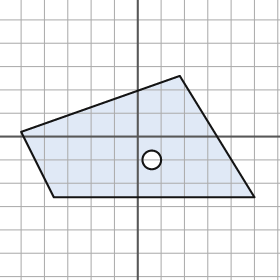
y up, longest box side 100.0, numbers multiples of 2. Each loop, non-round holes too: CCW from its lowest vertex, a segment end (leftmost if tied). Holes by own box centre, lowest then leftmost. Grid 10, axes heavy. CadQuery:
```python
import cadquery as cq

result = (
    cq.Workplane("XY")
    .moveTo(-36.0, -26.0)
    .lineTo(50.0, -26.0)
    .lineTo(18.0, 26.0)
    .lineTo(-50.0, 2.0)
    .close()
    .moveTo(6.0, -10.0)
    .circle(4.0)
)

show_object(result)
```